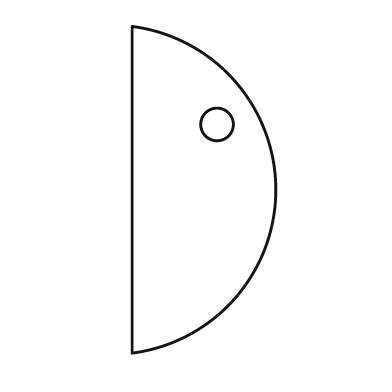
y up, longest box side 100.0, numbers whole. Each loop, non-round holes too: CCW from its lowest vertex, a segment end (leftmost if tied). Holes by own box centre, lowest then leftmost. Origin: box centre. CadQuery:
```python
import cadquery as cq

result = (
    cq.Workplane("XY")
    .moveTo(-22.0, -50.0)
    .threePointArc((22.0, 0.0), (-22.0, 50.0))
    .close()
    .moveTo(4.0, 20.0)
    .circle(5.0)
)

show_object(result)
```